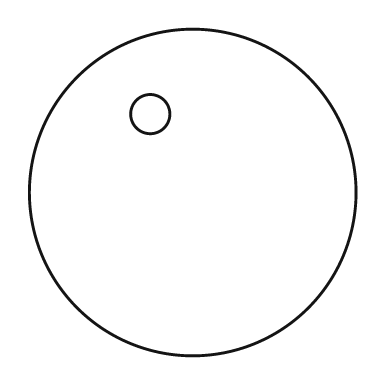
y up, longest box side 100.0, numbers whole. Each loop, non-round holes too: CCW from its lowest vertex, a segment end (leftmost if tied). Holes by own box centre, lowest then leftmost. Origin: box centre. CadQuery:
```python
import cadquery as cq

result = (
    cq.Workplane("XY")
    .moveTo(0.0, 0.0)
    .circle(50.0)
    .moveTo(-13.0, 24.0)
    .circle(6.0)
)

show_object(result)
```